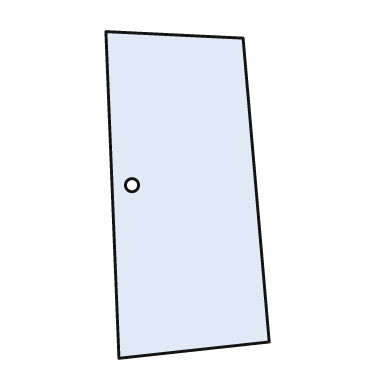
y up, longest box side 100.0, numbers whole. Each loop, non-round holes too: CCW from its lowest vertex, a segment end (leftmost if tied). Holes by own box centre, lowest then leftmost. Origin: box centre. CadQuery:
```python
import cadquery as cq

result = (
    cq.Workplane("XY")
    .moveTo(-21.0, -50.0)
    .lineTo(25.0, -45.0)
    .lineTo(17.0, 48.0)
    .lineTo(-25.0, 50.0)
    .close()
    .moveTo(-17.0, 3.0)
    .circle(2.0)
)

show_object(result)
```